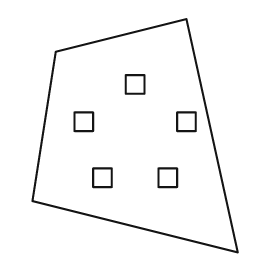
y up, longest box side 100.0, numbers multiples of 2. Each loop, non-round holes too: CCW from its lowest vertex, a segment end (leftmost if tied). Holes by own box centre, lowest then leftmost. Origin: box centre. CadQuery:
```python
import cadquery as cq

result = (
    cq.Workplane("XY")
    .moveTo(44.0, -50.0)
    .lineTo(22.0, 50.0)
    .lineTo(-34.0, 36.0)
    .lineTo(-44.0, -28.0)
    .close()
    .moveTo(-18.0, -22.0)
    .lineTo(-10.0, -22.0)
    .lineTo(-10.0, -14.0)
    .lineTo(-18.0, -14.0)
    .close()
    .moveTo(10.0, -22.0)
    .lineTo(18.0, -22.0)
    .lineTo(18.0, -14.0)
    .lineTo(10.0, -14.0)
    .close()
    .moveTo(-26.0, 2.0)
    .lineTo(-18.0, 2.0)
    .lineTo(-18.0, 10.0)
    .lineTo(-26.0, 10.0)
    .close()
    .moveTo(18.0, 2.0)
    .lineTo(26.0, 2.0)
    .lineTo(26.0, 10.0)
    .lineTo(18.0, 10.0)
    .close()
    .moveTo(-4.0, 18.0)
    .lineTo(4.0, 18.0)
    .lineTo(4.0, 26.0)
    .lineTo(-4.0, 26.0)
    .close()
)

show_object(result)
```